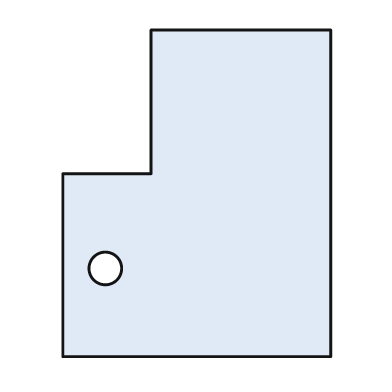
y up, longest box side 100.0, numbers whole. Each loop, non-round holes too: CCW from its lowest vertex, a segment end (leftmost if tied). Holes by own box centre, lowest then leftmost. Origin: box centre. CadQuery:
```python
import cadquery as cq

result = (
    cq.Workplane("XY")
    .moveTo(-41.0, -50.0)
    .lineTo(41.0, -50.0)
    .lineTo(41.0, 50.0)
    .lineTo(-14.0, 50.0)
    .lineTo(-14.0, 6.0)
    .lineTo(-41.0, 6.0)
    .close()
    .moveTo(-28.0, -23.0)
    .circle(5.0)
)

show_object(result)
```